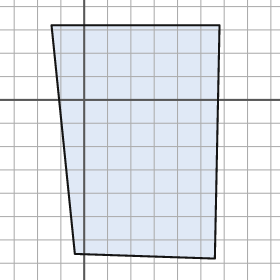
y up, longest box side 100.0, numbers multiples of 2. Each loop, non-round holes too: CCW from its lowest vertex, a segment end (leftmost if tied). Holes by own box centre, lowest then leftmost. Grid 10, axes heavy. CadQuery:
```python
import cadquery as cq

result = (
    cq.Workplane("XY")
    .moveTo(56.0, -68.0)
    .lineTo(58.0, 32.0)
    .lineTo(-14.0, 32.0)
    .lineTo(-4.0, -66.0)
    .close()
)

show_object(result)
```